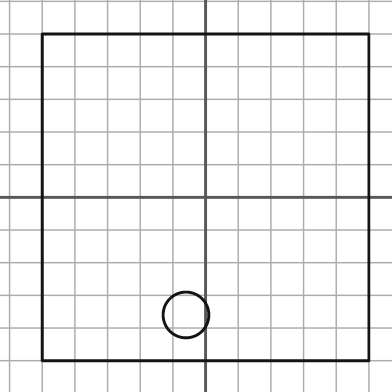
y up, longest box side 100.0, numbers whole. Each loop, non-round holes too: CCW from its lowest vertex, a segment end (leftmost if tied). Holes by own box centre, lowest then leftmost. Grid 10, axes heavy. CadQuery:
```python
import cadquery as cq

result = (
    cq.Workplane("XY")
    .moveTo(-50.0, -50.0)
    .lineTo(50.0, -50.0)
    .lineTo(50.0, 50.0)
    .lineTo(-50.0, 50.0)
    .close()
    .moveTo(-6.0, -36.0)
    .circle(7.0)
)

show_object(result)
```